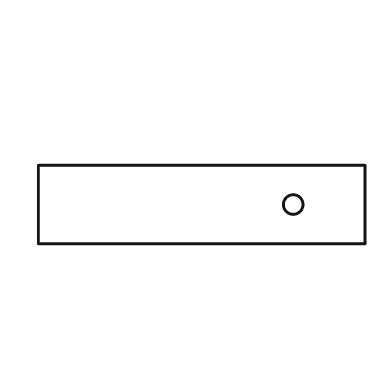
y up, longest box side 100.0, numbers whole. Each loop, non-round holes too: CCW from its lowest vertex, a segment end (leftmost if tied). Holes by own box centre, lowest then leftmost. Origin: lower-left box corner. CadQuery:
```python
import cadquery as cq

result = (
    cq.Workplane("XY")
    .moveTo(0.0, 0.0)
    .lineTo(100.0, 0.0)
    .lineTo(100.0, 24.0)
    .lineTo(0.0, 24.0)
    .close()
    .moveTo(78.0, 12.0)
    .circle(3.0)
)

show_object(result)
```